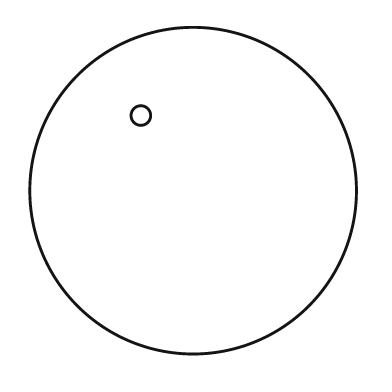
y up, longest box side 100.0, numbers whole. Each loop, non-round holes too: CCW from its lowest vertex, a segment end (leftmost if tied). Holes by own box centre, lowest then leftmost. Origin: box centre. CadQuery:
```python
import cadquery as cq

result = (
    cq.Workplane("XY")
    .moveTo(0.0, 0.0)
    .circle(50.0)
    .moveTo(-16.0, 23.0)
    .circle(3.0)
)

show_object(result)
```